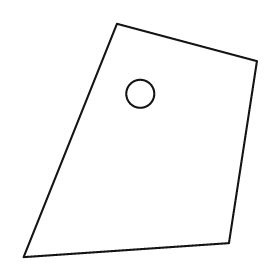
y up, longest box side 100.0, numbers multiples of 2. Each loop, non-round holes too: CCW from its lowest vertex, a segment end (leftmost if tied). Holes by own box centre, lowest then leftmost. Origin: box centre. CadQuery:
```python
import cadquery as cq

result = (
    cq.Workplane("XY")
    .moveTo(-50.0, -50.0)
    .lineTo(38.0, -44.0)
    .lineTo(50.0, 34.0)
    .lineTo(-10.0, 50.0)
    .close()
    .moveTo(0.0, 20.0)
    .circle(6.0)
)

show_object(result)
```